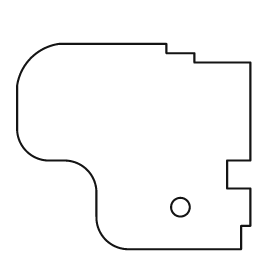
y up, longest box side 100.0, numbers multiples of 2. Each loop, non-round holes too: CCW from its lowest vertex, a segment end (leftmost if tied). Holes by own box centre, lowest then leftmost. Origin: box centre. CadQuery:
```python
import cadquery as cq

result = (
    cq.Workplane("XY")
    .moveTo(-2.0, -44.0)
    .lineTo(46.0, -44.0)
    .lineTo(46.0, -34.0)
    .lineTo(50.0, -34.0)
    .lineTo(50.0, -18.0)
    .lineTo(40.0, -18.0)
    .lineTo(40.0, -6.0)
    .lineTo(50.0, -6.0)
    .lineTo(50.0, 36.0)
    .lineTo(26.0, 36.0)
    .lineTo(26.0, 40.0)
    .lineTo(14.0, 40.0)
    .lineTo(14.0, 44.0)
    .lineTo(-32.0, 44.0)
    .threePointArc((-44.0, 38.0), (-50.0, 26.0))
    .lineTo(-50.0, 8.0)
    .threePointArc((-46.0, -2.0), (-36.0, -6.0))
    .lineTo(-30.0, -6.0)
    .threePointArc((-20.0, -10.0), (-16.0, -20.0))
    .lineTo(-16.0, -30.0)
    .threePointArc((-12.0, -40.0), (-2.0, -44.0))
    .close()
    .moveTo(20.0, -26.0)
    .circle(4.0)
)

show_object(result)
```